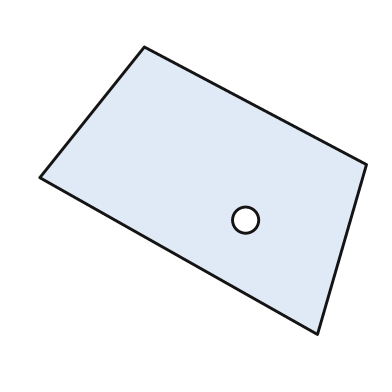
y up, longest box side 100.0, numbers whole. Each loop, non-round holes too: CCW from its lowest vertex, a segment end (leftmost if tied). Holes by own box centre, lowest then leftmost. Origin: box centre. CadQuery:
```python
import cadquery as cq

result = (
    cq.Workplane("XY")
    .moveTo(35.0, -44.0)
    .lineTo(50.0, 8.0)
    .lineTo(-18.0, 44.0)
    .lineTo(-50.0, 4.0)
    .close()
    .moveTo(13.0, -9.0)
    .circle(4.0)
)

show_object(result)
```